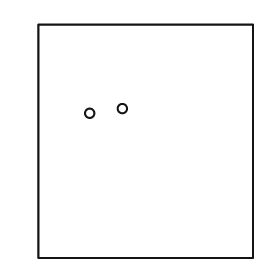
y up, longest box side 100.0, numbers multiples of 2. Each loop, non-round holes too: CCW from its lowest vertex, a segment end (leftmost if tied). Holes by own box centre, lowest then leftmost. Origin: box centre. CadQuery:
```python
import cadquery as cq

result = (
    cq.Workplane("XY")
    .moveTo(-46.0, -50.0)
    .lineTo(46.0, -50.0)
    .lineTo(46.0, 50.0)
    .lineTo(-46.0, 50.0)
    .close()
    .moveTo(-24.0, 12.0)
    .circle(2.0)
    .moveTo(-10.0, 14.0)
    .circle(2.0)
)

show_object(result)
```